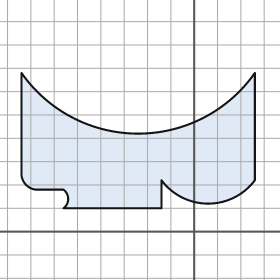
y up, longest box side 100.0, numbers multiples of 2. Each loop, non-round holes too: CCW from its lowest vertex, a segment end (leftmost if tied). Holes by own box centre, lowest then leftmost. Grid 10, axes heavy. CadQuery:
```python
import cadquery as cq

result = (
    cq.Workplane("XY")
    .moveTo(-56.0, 10.0)
    .lineTo(-14.0, 10.0)
    .lineTo(-14.0, 22.0)
    .threePointArc((6.0, 12.0), (26.0, 22.0))
    .lineTo(26.0, 68.0)
    .threePointArc((-24.0, 42.0), (-74.0, 68.0))
    .lineTo(-74.0, 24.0)
    .threePointArc((-72.0, 20.0), (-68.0, 18.0))
    .lineTo(-56.0, 18.0)
    .threePointArc((-54.0, 14.0), (-56.0, 10.0))
    .close()
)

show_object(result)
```